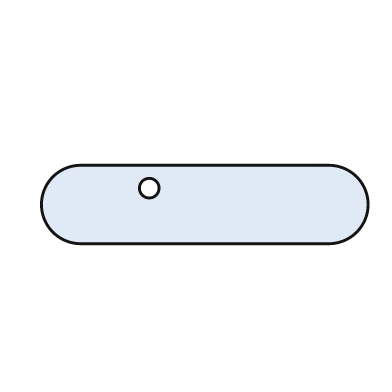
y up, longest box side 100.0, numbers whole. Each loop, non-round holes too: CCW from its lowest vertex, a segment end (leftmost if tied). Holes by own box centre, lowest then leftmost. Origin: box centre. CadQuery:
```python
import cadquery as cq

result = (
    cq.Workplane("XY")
    .moveTo(-38.0, -12.0)
    .lineTo(38.0, -12.0)
    .threePointArc((50.0, 0.0), (38.0, 12.0))
    .lineTo(-38.0, 12.0)
    .threePointArc((-50.0, 0.0), (-38.0, -12.0))
    .close()
    .moveTo(-17.0, 5.0)
    .circle(3.0)
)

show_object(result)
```